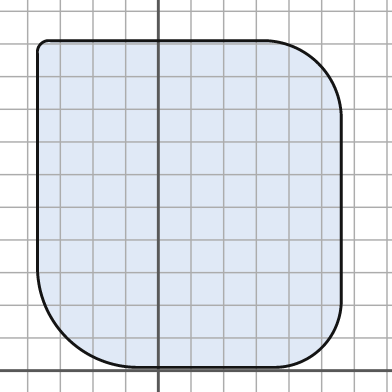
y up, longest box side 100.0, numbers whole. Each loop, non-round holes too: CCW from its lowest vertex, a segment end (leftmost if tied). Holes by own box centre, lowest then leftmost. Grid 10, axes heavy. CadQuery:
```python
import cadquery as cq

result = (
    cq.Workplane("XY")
    .moveTo(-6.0, 1.0)
    .lineTo(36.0, 1.0)
    .threePointArc((50.0, 7.0), (56.0, 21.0))
    .lineTo(56.0, 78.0)
    .threePointArc((49.0, 94.0), (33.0, 101.0))
    .lineTo(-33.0, 101.0)
    .threePointArc((-36.0, 100.0), (-37.0, 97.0))
    .lineTo(-37.0, 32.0)
    .threePointArc((-28.0, 10.0), (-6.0, 1.0))
    .close()
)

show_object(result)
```